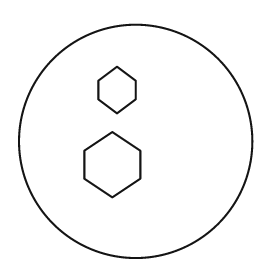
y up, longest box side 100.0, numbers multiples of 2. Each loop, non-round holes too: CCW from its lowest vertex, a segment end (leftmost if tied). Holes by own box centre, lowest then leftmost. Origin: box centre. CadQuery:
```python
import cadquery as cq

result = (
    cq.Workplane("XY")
    .moveTo(0.0, 0.0)
    .circle(50.0)
    .moveTo(-10.0, -24.0)
    .lineTo(2.0, -16.0)
    .lineTo(2.0, -4.0)
    .lineTo(-10.0, 4.0)
    .lineTo(-22.0, -4.0)
    .lineTo(-22.0, -16.0)
    .close()
    .moveTo(-8.0, 12.0)
    .lineTo(0.0, 18.0)
    .lineTo(0.0, 26.0)
    .lineTo(-8.0, 32.0)
    .lineTo(-16.0, 26.0)
    .lineTo(-16.0, 18.0)
    .close()
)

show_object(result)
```